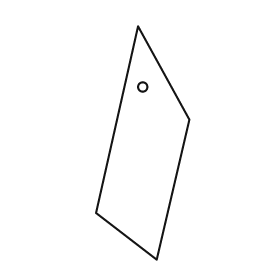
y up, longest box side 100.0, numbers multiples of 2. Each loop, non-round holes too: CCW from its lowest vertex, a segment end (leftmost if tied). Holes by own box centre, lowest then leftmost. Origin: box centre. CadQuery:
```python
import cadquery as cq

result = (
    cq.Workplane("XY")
    .moveTo(6.0, -50.0)
    .lineTo(20.0, 10.0)
    .lineTo(-2.0, 50.0)
    .lineTo(-20.0, -30.0)
    .close()
    .moveTo(0.0, 24.0)
    .circle(2.0)
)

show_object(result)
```